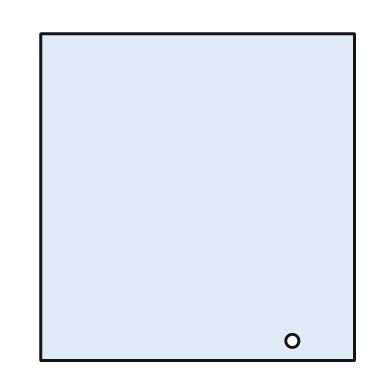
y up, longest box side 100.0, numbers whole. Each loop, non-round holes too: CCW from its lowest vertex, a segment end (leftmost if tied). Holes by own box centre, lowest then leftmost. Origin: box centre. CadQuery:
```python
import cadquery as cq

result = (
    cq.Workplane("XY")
    .moveTo(-48.0, -50.0)
    .lineTo(48.0, -50.0)
    .lineTo(48.0, 50.0)
    .lineTo(-48.0, 50.0)
    .close()
    .moveTo(29.0, -44.0)
    .circle(2.0)
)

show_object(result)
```